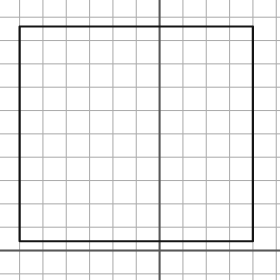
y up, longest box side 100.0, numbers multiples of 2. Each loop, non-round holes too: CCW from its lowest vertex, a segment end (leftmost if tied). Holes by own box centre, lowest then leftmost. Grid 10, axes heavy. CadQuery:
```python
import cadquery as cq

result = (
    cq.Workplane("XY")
    .moveTo(-60.0, 4.0)
    .lineTo(40.0, 4.0)
    .lineTo(40.0, 96.0)
    .lineTo(-60.0, 96.0)
    .close()
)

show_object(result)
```